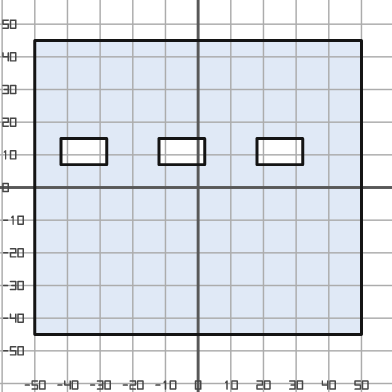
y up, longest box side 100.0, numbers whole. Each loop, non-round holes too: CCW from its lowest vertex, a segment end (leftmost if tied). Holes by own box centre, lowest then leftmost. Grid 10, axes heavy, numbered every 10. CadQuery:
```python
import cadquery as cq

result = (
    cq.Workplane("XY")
    .moveTo(-50.0, -45.0)
    .lineTo(50.0, -45.0)
    .lineTo(50.0, 45.0)
    .lineTo(-50.0, 45.0)
    .close()
    .moveTo(-42.0, 7.0)
    .lineTo(-28.0, 7.0)
    .lineTo(-28.0, 15.0)
    .lineTo(-42.0, 15.0)
    .close()
    .moveTo(-12.0, 7.0)
    .lineTo(2.0, 7.0)
    .lineTo(2.0, 15.0)
    .lineTo(-12.0, 15.0)
    .close()
    .moveTo(18.0, 7.0)
    .lineTo(32.0, 7.0)
    .lineTo(32.0, 15.0)
    .lineTo(18.0, 15.0)
    .close()
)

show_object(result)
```